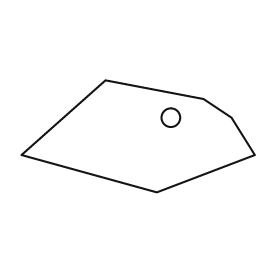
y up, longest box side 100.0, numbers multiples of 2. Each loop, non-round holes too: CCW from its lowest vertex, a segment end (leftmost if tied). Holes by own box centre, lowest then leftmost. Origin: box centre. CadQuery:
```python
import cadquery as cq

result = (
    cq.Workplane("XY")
    .moveTo(8.0, -24.0)
    .lineTo(50.0, -8.0)
    .lineTo(40.0, 8.0)
    .lineTo(28.0, 16.0)
    .lineTo(-14.0, 24.0)
    .lineTo(-50.0, -8.0)
    .close()
    .moveTo(14.0, 8.0)
    .circle(4.0)
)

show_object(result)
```